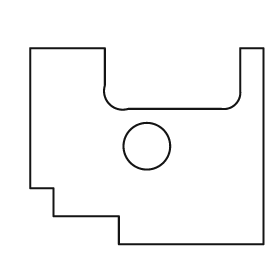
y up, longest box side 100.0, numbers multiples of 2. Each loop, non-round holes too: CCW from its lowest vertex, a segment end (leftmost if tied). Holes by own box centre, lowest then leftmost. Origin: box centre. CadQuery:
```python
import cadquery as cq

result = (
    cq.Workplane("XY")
    .moveTo(-12.0, -42.0)
    .lineTo(50.0, -42.0)
    .lineTo(50.0, 42.0)
    .lineTo(40.0, 42.0)
    .lineTo(40.0, 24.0)
    .threePointArc((38.0, 18.0), (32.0, 16.0))
    .lineTo(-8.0, 16.0)
    .threePointArc((-16.0, 18.0), (-18.0, 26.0))
    .lineTo(-18.0, 42.0)
    .lineTo(-50.0, 42.0)
    .lineTo(-50.0, -18.0)
    .lineTo(-40.0, -18.0)
    .lineTo(-40.0, -30.0)
    .lineTo(-12.0, -30.0)
    .close()
    .moveTo(0.0, 0.0)
    .circle(10.0)
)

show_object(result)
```